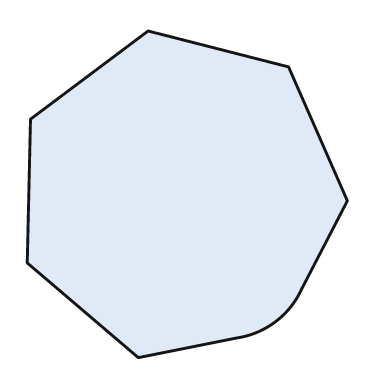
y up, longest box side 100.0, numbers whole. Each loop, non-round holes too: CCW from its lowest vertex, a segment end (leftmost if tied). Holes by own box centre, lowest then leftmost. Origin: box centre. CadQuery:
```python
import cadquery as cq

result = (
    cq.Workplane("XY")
    .moveTo(-15.0, -50.0)
    .lineTo(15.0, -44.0)
    .threePointArc((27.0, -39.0), (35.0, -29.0))
    .lineTo(49.0, -2.0)
    .lineTo(31.0, 39.0)
    .lineTo(-12.0, 50.0)
    .lineTo(-48.0, 23.0)
    .lineTo(-49.0, -21.0)
    .close()
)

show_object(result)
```